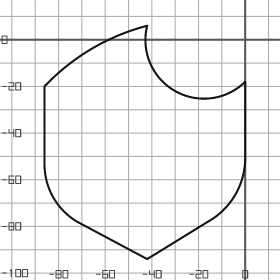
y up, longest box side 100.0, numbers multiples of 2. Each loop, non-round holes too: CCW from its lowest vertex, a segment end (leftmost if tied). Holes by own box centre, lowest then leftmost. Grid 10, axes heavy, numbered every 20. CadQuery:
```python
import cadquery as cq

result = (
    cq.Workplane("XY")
    .moveTo(-42.0, -94.0)
    .lineTo(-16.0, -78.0)
    .threePointArc((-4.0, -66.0), (0.0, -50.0))
    .lineTo(0.0, -18.0)
    .threePointArc((-30.0, -22.0), (-42.0, 6.0))
    .threePointArc((-66.0, -4.0), (-86.0, -20.0))
    .lineTo(-86.0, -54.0)
    .threePointArc((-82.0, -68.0), (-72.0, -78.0))
    .close()
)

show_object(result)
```